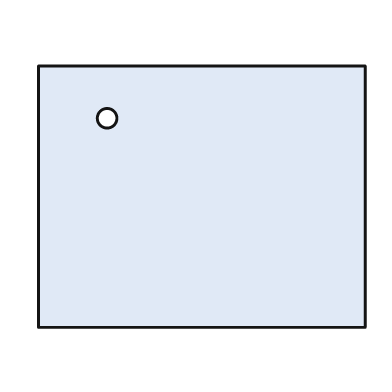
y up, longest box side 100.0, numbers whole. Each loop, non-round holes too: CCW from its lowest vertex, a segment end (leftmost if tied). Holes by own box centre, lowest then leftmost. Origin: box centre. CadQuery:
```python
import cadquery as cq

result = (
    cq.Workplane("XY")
    .moveTo(-50.0, -40.0)
    .lineTo(50.0, -40.0)
    .lineTo(50.0, 40.0)
    .lineTo(-50.0, 40.0)
    .close()
    .moveTo(-29.0, 24.0)
    .circle(3.0)
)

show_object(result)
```